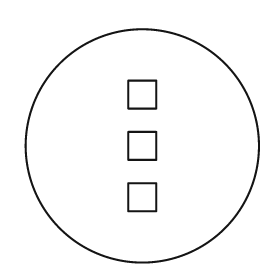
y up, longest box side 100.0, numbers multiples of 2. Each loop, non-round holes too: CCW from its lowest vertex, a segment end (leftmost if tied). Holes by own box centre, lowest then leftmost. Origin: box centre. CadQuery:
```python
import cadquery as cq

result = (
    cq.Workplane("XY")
    .moveTo(0.0, 0.0)
    .circle(50.0)
    .moveTo(-6.0, -28.0)
    .lineTo(6.0, -28.0)
    .lineTo(6.0, -16.0)
    .lineTo(-6.0, -16.0)
    .close()
    .moveTo(-6.0, -6.0)
    .lineTo(6.0, -6.0)
    .lineTo(6.0, 6.0)
    .lineTo(-6.0, 6.0)
    .close()
    .moveTo(-6.0, 16.0)
    .lineTo(6.0, 16.0)
    .lineTo(6.0, 28.0)
    .lineTo(-6.0, 28.0)
    .close()
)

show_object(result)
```